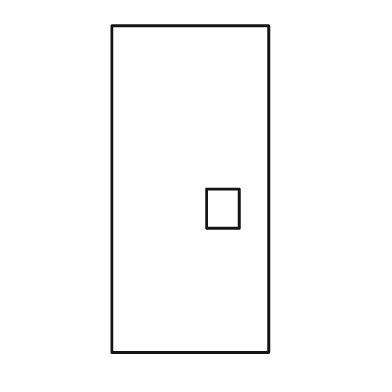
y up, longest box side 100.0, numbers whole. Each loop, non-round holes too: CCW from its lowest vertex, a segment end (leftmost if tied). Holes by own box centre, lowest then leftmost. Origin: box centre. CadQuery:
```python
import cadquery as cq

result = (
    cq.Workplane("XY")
    .moveTo(-24.0, -50.0)
    .lineTo(24.0, -50.0)
    .lineTo(24.0, 50.0)
    .lineTo(-24.0, 50.0)
    .close()
    .moveTo(5.0, -12.0)
    .lineTo(15.0, -12.0)
    .lineTo(15.0, 0.0)
    .lineTo(5.0, 0.0)
    .close()
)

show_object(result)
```